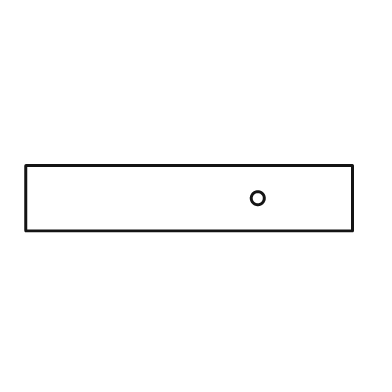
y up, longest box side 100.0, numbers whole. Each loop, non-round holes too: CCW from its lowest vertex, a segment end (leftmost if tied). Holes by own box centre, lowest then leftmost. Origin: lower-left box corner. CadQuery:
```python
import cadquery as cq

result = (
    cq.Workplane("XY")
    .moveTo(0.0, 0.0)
    .lineTo(100.0, 0.0)
    .lineTo(100.0, 20.0)
    .lineTo(0.0, 20.0)
    .close()
    .moveTo(71.0, 10.0)
    .circle(2.0)
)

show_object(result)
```